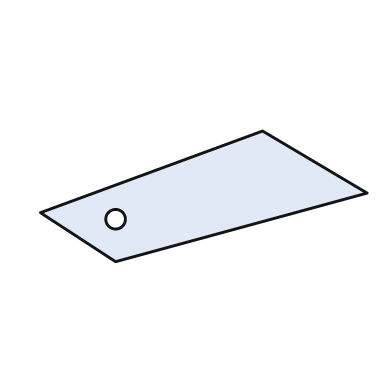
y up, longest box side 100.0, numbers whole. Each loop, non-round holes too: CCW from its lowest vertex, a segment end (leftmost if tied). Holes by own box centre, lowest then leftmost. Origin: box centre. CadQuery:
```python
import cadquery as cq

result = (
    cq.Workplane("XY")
    .moveTo(-27.0, -20.0)
    .lineTo(50.0, 1.0)
    .lineTo(18.0, 20.0)
    .lineTo(-50.0, -5.0)
    .close()
    .moveTo(-27.0, -7.0)
    .circle(3.0)
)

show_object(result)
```